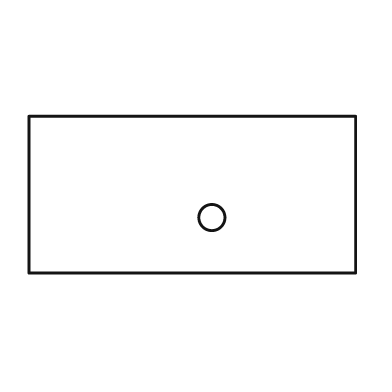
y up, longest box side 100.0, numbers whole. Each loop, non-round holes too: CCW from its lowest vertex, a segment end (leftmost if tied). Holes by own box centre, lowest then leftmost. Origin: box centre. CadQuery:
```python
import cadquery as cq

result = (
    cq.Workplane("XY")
    .moveTo(-50.0, -24.0)
    .lineTo(50.0, -24.0)
    .lineTo(50.0, 24.0)
    .lineTo(-50.0, 24.0)
    .close()
    .moveTo(6.0, -7.0)
    .circle(4.0)
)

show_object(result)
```